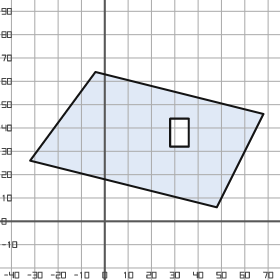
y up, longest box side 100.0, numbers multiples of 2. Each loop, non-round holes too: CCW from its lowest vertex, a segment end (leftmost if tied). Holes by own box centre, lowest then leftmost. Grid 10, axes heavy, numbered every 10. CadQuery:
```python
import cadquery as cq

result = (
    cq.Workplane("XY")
    .moveTo(48.0, 6.0)
    .lineTo(68.0, 46.0)
    .lineTo(-4.0, 64.0)
    .lineTo(-32.0, 26.0)
    .close()
    .moveTo(28.0, 32.0)
    .lineTo(36.0, 32.0)
    .lineTo(36.0, 44.0)
    .lineTo(28.0, 44.0)
    .close()
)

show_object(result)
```